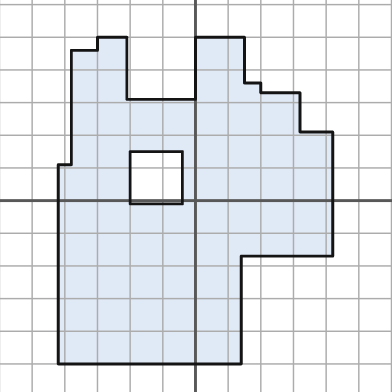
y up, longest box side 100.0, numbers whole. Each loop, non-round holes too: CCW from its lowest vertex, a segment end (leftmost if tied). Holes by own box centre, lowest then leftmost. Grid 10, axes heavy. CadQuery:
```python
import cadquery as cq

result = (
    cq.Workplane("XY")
    .moveTo(-42.0, -50.0)
    .lineTo(14.0, -50.0)
    .lineTo(14.0, -17.0)
    .lineTo(42.0, -17.0)
    .lineTo(42.0, 21.0)
    .lineTo(32.0, 21.0)
    .lineTo(32.0, 33.0)
    .lineTo(20.0, 33.0)
    .lineTo(20.0, 36.0)
    .lineTo(15.0, 36.0)
    .lineTo(15.0, 50.0)
    .lineTo(0.0, 50.0)
    .lineTo(0.0, 31.0)
    .lineTo(-21.0, 31.0)
    .lineTo(-21.0, 50.0)
    .lineTo(-30.0, 50.0)
    .lineTo(-30.0, 46.0)
    .lineTo(-38.0, 46.0)
    .lineTo(-38.0, 11.0)
    .lineTo(-42.0, 11.0)
    .close()
    .moveTo(-20.0, -1.0)
    .lineTo(-4.0, -1.0)
    .lineTo(-4.0, 15.0)
    .lineTo(-20.0, 15.0)
    .close()
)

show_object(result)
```